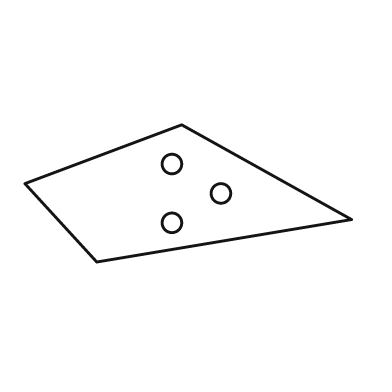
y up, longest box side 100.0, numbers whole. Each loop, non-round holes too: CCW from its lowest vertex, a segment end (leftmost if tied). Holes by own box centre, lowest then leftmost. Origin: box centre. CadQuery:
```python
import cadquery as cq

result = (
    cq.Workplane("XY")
    .moveTo(-28.0, -21.0)
    .lineTo(50.0, -8.0)
    .lineTo(-2.0, 21.0)
    .lineTo(-50.0, 3.0)
    .close()
    .moveTo(-5.0, -9.0)
    .circle(3.0)
    .moveTo(10.0, 0.0)
    .circle(3.0)
    .moveTo(-5.0, 9.0)
    .circle(3.0)
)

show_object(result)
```